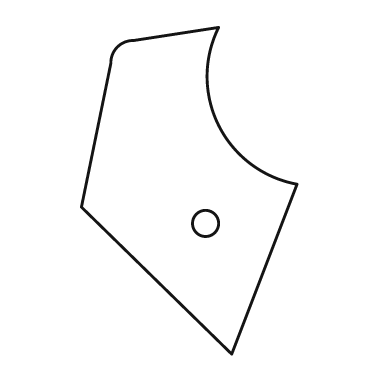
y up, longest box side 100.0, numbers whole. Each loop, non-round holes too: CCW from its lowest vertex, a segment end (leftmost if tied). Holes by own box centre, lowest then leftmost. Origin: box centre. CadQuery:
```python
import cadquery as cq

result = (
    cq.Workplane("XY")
    .moveTo(13.0, -50.0)
    .lineTo(33.0, 2.0)
    .threePointArc((9.0, 20.0), (9.0, 50.0))
    .lineTo(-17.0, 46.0)
    .threePointArc((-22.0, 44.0), (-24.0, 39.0))
    .lineTo(-33.0, -5.0)
    .close()
    .moveTo(5.0, -10.0)
    .circle(4.0)
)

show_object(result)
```